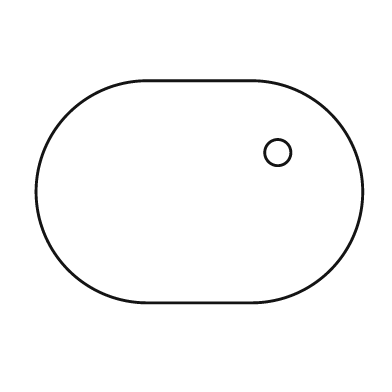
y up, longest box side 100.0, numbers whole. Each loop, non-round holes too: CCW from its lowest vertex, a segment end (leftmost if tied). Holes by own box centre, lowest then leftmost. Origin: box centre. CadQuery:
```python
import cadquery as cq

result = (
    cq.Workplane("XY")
    .moveTo(-16.0, -34.0)
    .lineTo(16.0, -34.0)
    .threePointArc((50.0, 0.0), (16.0, 34.0))
    .lineTo(-16.0, 34.0)
    .threePointArc((-50.0, 0.0), (-16.0, -34.0))
    .close()
    .moveTo(24.0, 12.0)
    .circle(4.0)
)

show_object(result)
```